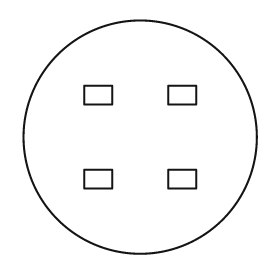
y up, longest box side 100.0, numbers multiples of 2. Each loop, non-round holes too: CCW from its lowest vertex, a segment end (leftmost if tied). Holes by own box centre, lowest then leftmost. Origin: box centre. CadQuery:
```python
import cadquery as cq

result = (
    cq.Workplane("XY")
    .moveTo(0.0, 0.0)
    .circle(50.0)
    .moveTo(-24.0, -22.0)
    .lineTo(-12.0, -22.0)
    .lineTo(-12.0, -14.0)
    .lineTo(-24.0, -14.0)
    .close()
    .moveTo(12.0, -22.0)
    .lineTo(24.0, -22.0)
    .lineTo(24.0, -14.0)
    .lineTo(12.0, -14.0)
    .close()
    .moveTo(-24.0, 14.0)
    .lineTo(-12.0, 14.0)
    .lineTo(-12.0, 22.0)
    .lineTo(-24.0, 22.0)
    .close()
    .moveTo(12.0, 14.0)
    .lineTo(24.0, 14.0)
    .lineTo(24.0, 22.0)
    .lineTo(12.0, 22.0)
    .close()
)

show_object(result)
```